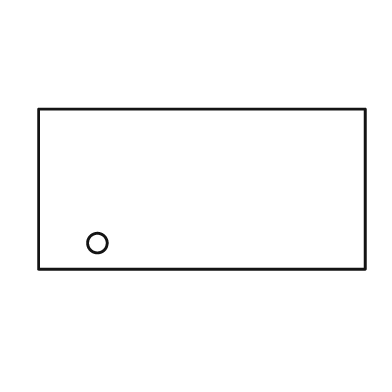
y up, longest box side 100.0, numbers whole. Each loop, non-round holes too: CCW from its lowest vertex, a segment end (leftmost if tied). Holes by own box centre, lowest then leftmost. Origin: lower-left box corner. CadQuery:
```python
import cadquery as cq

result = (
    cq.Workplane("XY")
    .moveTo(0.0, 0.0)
    .lineTo(100.0, 0.0)
    .lineTo(100.0, 49.0)
    .lineTo(0.0, 49.0)
    .close()
    .moveTo(18.0, 8.0)
    .circle(3.0)
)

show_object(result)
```